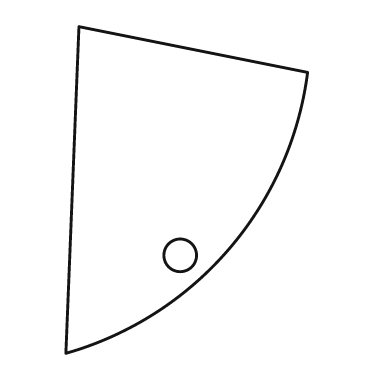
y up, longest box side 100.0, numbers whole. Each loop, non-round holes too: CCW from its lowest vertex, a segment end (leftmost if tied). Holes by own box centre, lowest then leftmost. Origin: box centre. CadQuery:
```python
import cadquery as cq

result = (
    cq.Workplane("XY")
    .moveTo(-37.0, -50.0)
    .threePointArc((13.0, -18.0), (37.0, 36.0))
    .lineTo(-33.0, 50.0)
    .close()
    .moveTo(-2.0, -20.0)
    .circle(5.0)
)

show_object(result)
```